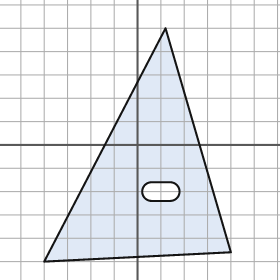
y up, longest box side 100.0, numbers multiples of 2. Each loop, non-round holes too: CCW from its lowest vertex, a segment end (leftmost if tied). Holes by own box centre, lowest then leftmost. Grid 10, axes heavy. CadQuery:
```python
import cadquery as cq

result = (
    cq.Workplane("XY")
    .moveTo(-40.0, -50.0)
    .lineTo(40.0, -46.0)
    .lineTo(12.0, 50.0)
    .close()
    .moveTo(6.0, -24.0)
    .lineTo(14.0, -24.0)
    .threePointArc((18.0, -20.0), (14.0, -16.0))
    .lineTo(6.0, -16.0)
    .threePointArc((2.0, -20.0), (6.0, -24.0))
    .close()
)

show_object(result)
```